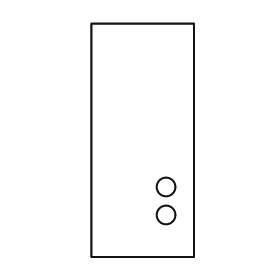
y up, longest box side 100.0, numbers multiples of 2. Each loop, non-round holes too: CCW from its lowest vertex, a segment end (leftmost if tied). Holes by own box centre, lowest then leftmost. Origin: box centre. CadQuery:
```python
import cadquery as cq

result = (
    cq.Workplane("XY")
    .moveTo(-22.0, -50.0)
    .lineTo(22.0, -50.0)
    .lineTo(22.0, 50.0)
    .lineTo(-22.0, 50.0)
    .close()
    .moveTo(10.0, -32.0)
    .circle(4.0)
    .moveTo(10.0, -20.0)
    .circle(4.0)
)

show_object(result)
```